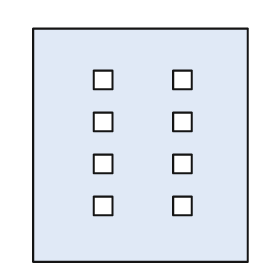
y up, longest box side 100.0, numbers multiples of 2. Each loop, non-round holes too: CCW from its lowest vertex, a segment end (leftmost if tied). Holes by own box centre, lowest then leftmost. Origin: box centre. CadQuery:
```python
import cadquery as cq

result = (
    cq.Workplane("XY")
    .moveTo(-46.0, -50.0)
    .lineTo(46.0, -50.0)
    .lineTo(46.0, 50.0)
    .lineTo(-46.0, 50.0)
    .close()
    .moveTo(-20.0, -30.0)
    .lineTo(-12.0, -30.0)
    .lineTo(-12.0, -22.0)
    .lineTo(-20.0, -22.0)
    .close()
    .moveTo(14.0, -30.0)
    .lineTo(22.0, -30.0)
    .lineTo(22.0, -22.0)
    .lineTo(14.0, -22.0)
    .close()
    .moveTo(-20.0, -12.0)
    .lineTo(-12.0, -12.0)
    .lineTo(-12.0, -4.0)
    .lineTo(-20.0, -4.0)
    .close()
    .moveTo(14.0, -12.0)
    .lineTo(22.0, -12.0)
    .lineTo(22.0, -4.0)
    .lineTo(14.0, -4.0)
    .close()
    .moveTo(-20.0, 6.0)
    .lineTo(-12.0, 6.0)
    .lineTo(-12.0, 14.0)
    .lineTo(-20.0, 14.0)
    .close()
    .moveTo(14.0, 6.0)
    .lineTo(22.0, 6.0)
    .lineTo(22.0, 14.0)
    .lineTo(14.0, 14.0)
    .close()
    .moveTo(-20.0, 24.0)
    .lineTo(-12.0, 24.0)
    .lineTo(-12.0, 32.0)
    .lineTo(-20.0, 32.0)
    .close()
    .moveTo(14.0, 24.0)
    .lineTo(22.0, 24.0)
    .lineTo(22.0, 32.0)
    .lineTo(14.0, 32.0)
    .close()
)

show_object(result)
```